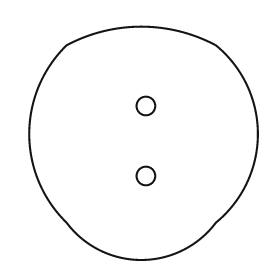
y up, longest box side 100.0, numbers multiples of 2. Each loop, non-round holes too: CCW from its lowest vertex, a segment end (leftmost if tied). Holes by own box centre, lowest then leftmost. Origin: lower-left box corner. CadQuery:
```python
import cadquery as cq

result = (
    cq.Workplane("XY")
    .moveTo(16.0, 16.0)
    .threePointArc((48.0, 0.0), (80.0, 16.0))
    .threePointArc((98.0, 54.0), (80.0, 92.0))
    .threePointArc((48.0, 100.0), (16.0, 92.0))
    .threePointArc((0.0, 54.0), (16.0, 16.0))
    .close()
    .moveTo(50.0, 36.0)
    .circle(4.0)
    .moveTo(50.0, 66.0)
    .circle(4.0)
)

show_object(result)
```